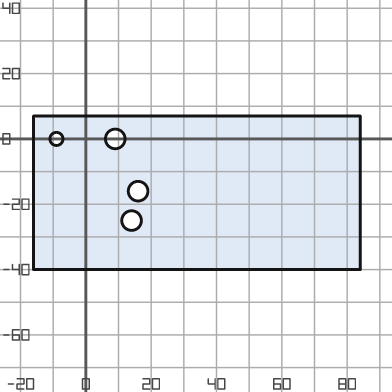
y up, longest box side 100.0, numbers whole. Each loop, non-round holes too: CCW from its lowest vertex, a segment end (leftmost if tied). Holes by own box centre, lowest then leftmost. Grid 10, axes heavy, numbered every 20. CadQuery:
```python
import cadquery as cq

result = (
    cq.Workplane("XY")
    .moveTo(-16.0, -40.0)
    .lineTo(84.0, -40.0)
    .lineTo(84.0, 7.0)
    .lineTo(-16.0, 7.0)
    .close()
    .moveTo(14.0, -25.0)
    .circle(3.0)
    .moveTo(16.0, -16.0)
    .circle(3.0)
    .moveTo(-9.0, 0.0)
    .circle(2.0)
    .moveTo(9.0, 0.0)
    .circle(3.0)
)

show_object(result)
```